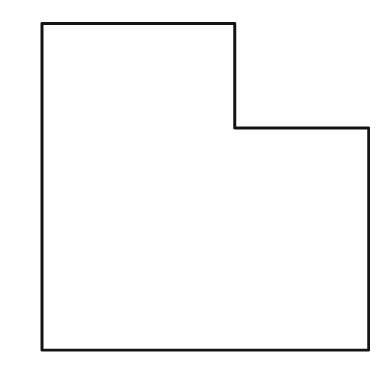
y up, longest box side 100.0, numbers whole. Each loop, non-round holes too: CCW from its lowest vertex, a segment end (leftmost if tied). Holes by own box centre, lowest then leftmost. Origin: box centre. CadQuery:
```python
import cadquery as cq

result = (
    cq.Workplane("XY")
    .moveTo(-50.0, -50.0)
    .lineTo(50.0, -50.0)
    .lineTo(50.0, 18.0)
    .lineTo(9.0, 18.0)
    .lineTo(9.0, 50.0)
    .lineTo(-50.0, 50.0)
    .close()
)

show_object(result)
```